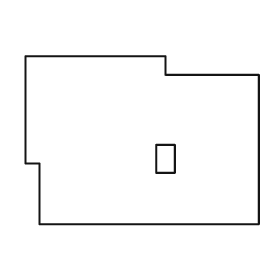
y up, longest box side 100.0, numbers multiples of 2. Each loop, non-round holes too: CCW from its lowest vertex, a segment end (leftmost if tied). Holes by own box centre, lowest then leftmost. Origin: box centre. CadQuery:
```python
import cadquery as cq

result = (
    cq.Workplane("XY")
    .moveTo(-44.0, -36.0)
    .lineTo(50.0, -36.0)
    .lineTo(50.0, 28.0)
    .lineTo(10.0, 28.0)
    .lineTo(10.0, 36.0)
    .lineTo(-50.0, 36.0)
    .lineTo(-50.0, -10.0)
    .lineTo(-44.0, -10.0)
    .close()
    .moveTo(6.0, -14.0)
    .lineTo(14.0, -14.0)
    .lineTo(14.0, -2.0)
    .lineTo(6.0, -2.0)
    .close()
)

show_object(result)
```